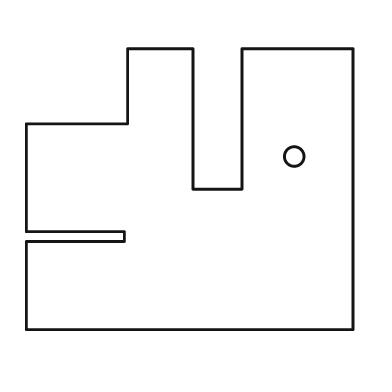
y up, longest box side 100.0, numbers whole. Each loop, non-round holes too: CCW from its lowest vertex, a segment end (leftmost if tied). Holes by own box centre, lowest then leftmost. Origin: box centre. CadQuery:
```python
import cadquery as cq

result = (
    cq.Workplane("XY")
    .moveTo(-50.0, -43.0)
    .lineTo(50.0, -43.0)
    .lineTo(50.0, 43.0)
    .lineTo(16.0, 43.0)
    .lineTo(16.0, 0.0)
    .lineTo(1.0, 0.0)
    .lineTo(1.0, 43.0)
    .lineTo(-19.0, 43.0)
    .lineTo(-19.0, 20.0)
    .lineTo(-50.0, 20.0)
    .lineTo(-50.0, -13.0)
    .lineTo(-20.0, -13.0)
    .lineTo(-20.0, -16.0)
    .lineTo(-50.0, -16.0)
    .close()
    .moveTo(32.0, 10.0)
    .circle(3.0)
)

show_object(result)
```